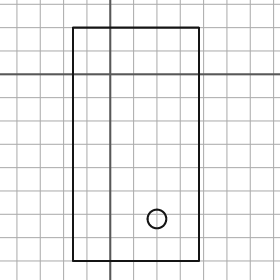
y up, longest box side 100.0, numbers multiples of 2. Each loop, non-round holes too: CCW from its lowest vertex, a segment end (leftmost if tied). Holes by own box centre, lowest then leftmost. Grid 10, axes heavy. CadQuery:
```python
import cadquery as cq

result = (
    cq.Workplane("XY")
    .moveTo(-16.0, -80.0)
    .lineTo(38.0, -80.0)
    .lineTo(38.0, 20.0)
    .lineTo(-16.0, 20.0)
    .close()
    .moveTo(20.0, -62.0)
    .circle(4.0)
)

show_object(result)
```